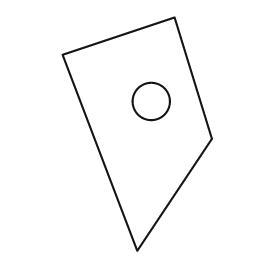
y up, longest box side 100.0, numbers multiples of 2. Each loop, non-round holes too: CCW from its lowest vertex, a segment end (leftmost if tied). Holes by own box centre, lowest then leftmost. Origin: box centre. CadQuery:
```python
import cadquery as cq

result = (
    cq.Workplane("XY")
    .moveTo(0.0, -50.0)
    .lineTo(32.0, -2.0)
    .lineTo(16.0, 50.0)
    .lineTo(-32.0, 34.0)
    .close()
    .moveTo(6.0, 14.0)
    .circle(8.0)
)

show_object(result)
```